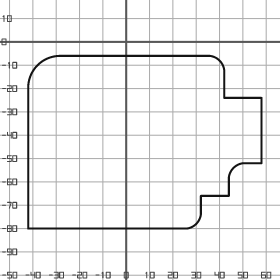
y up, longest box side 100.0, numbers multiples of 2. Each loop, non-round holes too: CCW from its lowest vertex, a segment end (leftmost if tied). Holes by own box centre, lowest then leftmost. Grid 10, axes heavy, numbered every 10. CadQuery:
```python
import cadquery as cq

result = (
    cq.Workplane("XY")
    .moveTo(-42.0, -80.0)
    .lineTo(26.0, -80.0)
    .threePointArc((30.0, -78.0), (32.0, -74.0))
    .lineTo(32.0, -66.0)
    .lineTo(44.0, -66.0)
    .lineTo(44.0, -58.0)
    .threePointArc((46.0, -54.0), (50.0, -52.0))
    .lineTo(58.0, -52.0)
    .lineTo(58.0, -24.0)
    .lineTo(42.0, -24.0)
    .lineTo(42.0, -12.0)
    .threePointArc((40.0, -8.0), (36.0, -6.0))
    .lineTo(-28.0, -6.0)
    .threePointArc((-38.0, -10.0), (-42.0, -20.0))
    .close()
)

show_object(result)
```